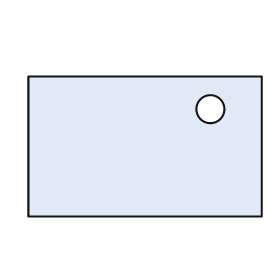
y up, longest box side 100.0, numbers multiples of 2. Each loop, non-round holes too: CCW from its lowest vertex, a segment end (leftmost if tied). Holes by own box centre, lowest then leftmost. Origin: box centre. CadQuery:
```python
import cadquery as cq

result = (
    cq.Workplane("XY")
    .moveTo(-50.0, -30.0)
    .lineTo(50.0, -30.0)
    .lineTo(50.0, 30.0)
    .lineTo(-50.0, 30.0)
    .close()
    .moveTo(28.0, 16.0)
    .circle(6.0)
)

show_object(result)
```